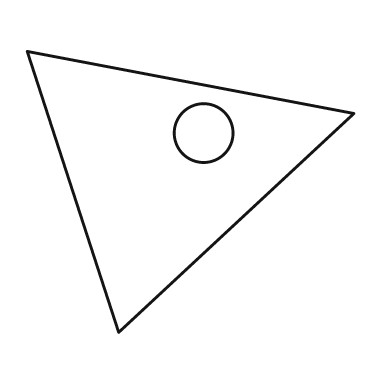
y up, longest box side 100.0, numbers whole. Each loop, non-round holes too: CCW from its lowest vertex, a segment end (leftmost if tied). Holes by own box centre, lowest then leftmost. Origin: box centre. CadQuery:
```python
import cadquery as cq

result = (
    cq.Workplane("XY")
    .moveTo(-22.0, -43.0)
    .lineTo(50.0, 24.0)
    .lineTo(-50.0, 43.0)
    .close()
    .moveTo(4.0, 18.0)
    .circle(9.0)
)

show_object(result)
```